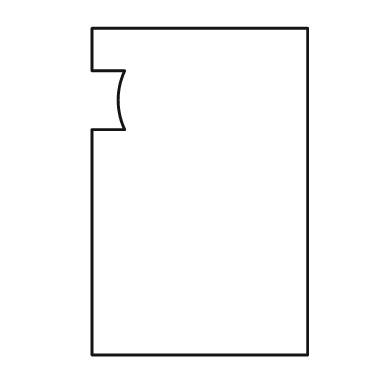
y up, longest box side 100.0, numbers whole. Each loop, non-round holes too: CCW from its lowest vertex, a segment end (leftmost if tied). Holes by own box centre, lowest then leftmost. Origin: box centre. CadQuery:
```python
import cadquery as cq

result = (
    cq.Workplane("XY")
    .moveTo(-33.0, -50.0)
    .lineTo(33.0, -50.0)
    .lineTo(33.0, 50.0)
    .lineTo(-33.0, 50.0)
    .lineTo(-33.0, 37.0)
    .lineTo(-23.0, 37.0)
    .threePointArc((-25.0, 28.0), (-23.0, 19.0))
    .lineTo(-33.0, 19.0)
    .close()
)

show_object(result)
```